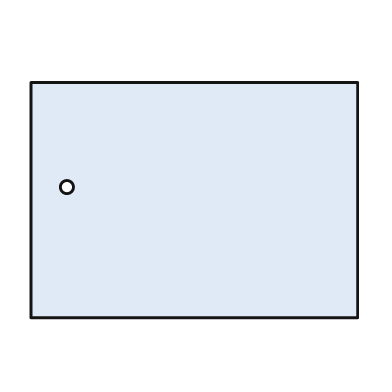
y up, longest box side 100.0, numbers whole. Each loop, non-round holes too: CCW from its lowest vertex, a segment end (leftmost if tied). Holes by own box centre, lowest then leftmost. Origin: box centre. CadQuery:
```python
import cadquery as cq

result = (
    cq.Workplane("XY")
    .moveTo(-50.0, -36.0)
    .lineTo(50.0, -36.0)
    .lineTo(50.0, 36.0)
    .lineTo(-50.0, 36.0)
    .close()
    .moveTo(-39.0, 4.0)
    .circle(2.0)
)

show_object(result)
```